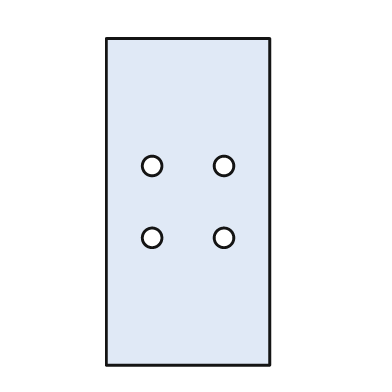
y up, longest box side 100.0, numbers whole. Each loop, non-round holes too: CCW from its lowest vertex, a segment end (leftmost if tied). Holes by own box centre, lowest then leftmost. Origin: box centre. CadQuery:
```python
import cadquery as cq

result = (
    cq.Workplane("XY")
    .moveTo(-25.0, -50.0)
    .lineTo(25.0, -50.0)
    .lineTo(25.0, 50.0)
    .lineTo(-25.0, 50.0)
    .close()
    .moveTo(-11.0, -11.0)
    .circle(3.0)
    .moveTo(11.0, -11.0)
    .circle(3.0)
    .moveTo(-11.0, 11.0)
    .circle(3.0)
    .moveTo(11.0, 11.0)
    .circle(3.0)
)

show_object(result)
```